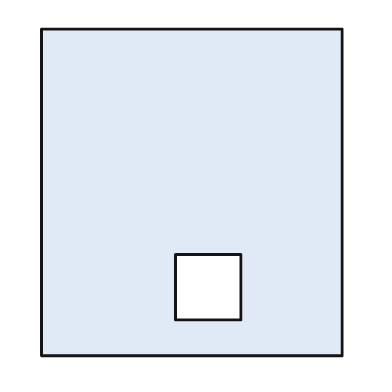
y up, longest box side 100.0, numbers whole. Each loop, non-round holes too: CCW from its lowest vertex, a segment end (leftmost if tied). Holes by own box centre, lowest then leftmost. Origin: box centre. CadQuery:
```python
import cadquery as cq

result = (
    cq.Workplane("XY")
    .moveTo(-46.0, -50.0)
    .lineTo(46.0, -50.0)
    .lineTo(46.0, 50.0)
    .lineTo(-46.0, 50.0)
    .close()
    .moveTo(-5.0, -39.0)
    .lineTo(15.0, -39.0)
    .lineTo(15.0, -19.0)
    .lineTo(-5.0, -19.0)
    .close()
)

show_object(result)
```